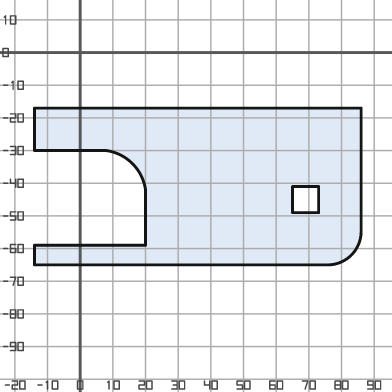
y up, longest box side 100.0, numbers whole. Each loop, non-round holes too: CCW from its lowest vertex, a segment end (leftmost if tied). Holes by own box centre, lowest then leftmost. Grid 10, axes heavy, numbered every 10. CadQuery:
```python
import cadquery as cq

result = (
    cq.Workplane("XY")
    .moveTo(-14.0, -65.0)
    .lineTo(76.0, -65.0)
    .threePointArc((83.0, -62.0), (86.0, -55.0))
    .lineTo(86.0, -17.0)
    .lineTo(-14.0, -17.0)
    .lineTo(-14.0, -30.0)
    .lineTo(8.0, -30.0)
    .threePointArc((16.0, -34.0), (20.0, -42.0))
    .lineTo(20.0, -59.0)
    .lineTo(-14.0, -59.0)
    .close()
    .moveTo(65.0, -49.0)
    .lineTo(73.0, -49.0)
    .lineTo(73.0, -41.0)
    .lineTo(65.0, -41.0)
    .close()
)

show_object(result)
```